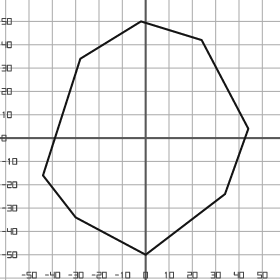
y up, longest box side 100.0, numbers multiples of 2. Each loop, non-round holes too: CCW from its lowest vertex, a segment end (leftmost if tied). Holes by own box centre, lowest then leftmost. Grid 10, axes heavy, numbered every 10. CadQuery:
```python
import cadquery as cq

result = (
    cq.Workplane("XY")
    .moveTo(0.0, -50.0)
    .lineTo(34.0, -24.0)
    .lineTo(44.0, 4.0)
    .lineTo(24.0, 42.0)
    .lineTo(-2.0, 50.0)
    .lineTo(-28.0, 34.0)
    .lineTo(-44.0, -16.0)
    .lineTo(-30.0, -34.0)
    .close()
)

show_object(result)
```